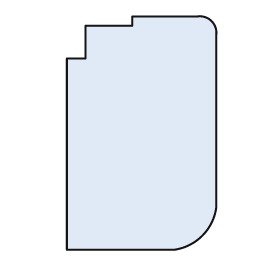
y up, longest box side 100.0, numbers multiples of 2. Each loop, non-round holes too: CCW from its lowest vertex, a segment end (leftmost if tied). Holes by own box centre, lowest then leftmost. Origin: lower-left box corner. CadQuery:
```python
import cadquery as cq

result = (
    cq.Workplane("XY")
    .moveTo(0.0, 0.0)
    .lineTo(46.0, 0.0)
    .threePointArc((58.0, 6.0), (64.0, 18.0))
    .lineTo(64.0, 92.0)
    .threePointArc((62.0, 98.0), (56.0, 100.0))
    .lineTo(28.0, 100.0)
    .lineTo(28.0, 96.0)
    .lineTo(8.0, 96.0)
    .lineTo(8.0, 82.0)
    .lineTo(0.0, 82.0)
    .close()
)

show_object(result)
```